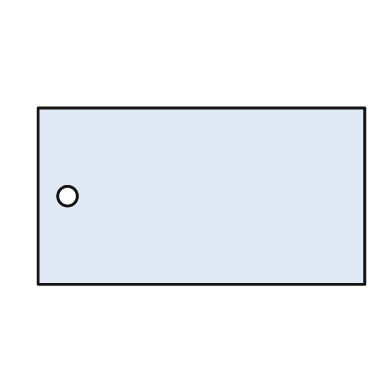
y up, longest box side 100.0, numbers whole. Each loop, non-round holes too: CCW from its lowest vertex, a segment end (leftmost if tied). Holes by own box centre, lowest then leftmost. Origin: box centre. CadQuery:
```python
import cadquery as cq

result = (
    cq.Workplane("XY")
    .moveTo(-50.0, -27.0)
    .lineTo(50.0, -27.0)
    .lineTo(50.0, 27.0)
    .lineTo(-50.0, 27.0)
    .close()
    .moveTo(-41.0, 0.0)
    .circle(3.0)
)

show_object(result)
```